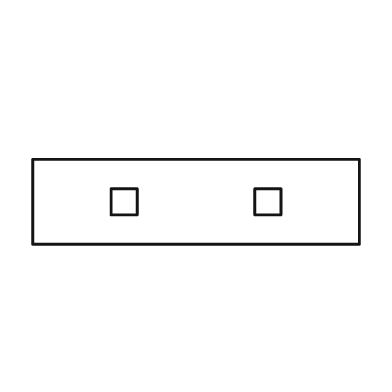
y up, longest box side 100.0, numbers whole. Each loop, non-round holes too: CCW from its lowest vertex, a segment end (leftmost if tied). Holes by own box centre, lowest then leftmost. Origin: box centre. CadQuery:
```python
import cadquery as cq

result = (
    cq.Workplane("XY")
    .moveTo(-50.0, -13.0)
    .lineTo(50.0, -13.0)
    .lineTo(50.0, 13.0)
    .lineTo(-50.0, 13.0)
    .close()
    .moveTo(-26.0, -4.0)
    .lineTo(-18.0, -4.0)
    .lineTo(-18.0, 4.0)
    .lineTo(-26.0, 4.0)
    .close()
    .moveTo(18.0, -4.0)
    .lineTo(26.0, -4.0)
    .lineTo(26.0, 4.0)
    .lineTo(18.0, 4.0)
    .close()
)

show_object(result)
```